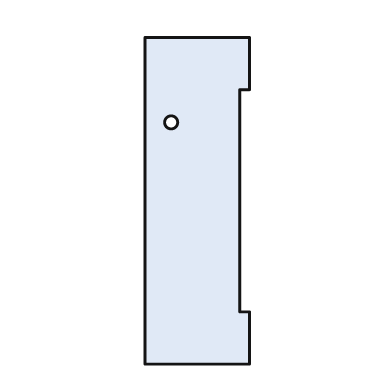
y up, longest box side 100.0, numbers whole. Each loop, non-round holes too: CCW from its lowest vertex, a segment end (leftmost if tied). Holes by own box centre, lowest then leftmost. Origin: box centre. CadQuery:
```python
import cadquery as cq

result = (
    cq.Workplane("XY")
    .moveTo(-16.0, -50.0)
    .lineTo(16.0, -50.0)
    .lineTo(16.0, -34.0)
    .lineTo(13.0, -34.0)
    .lineTo(13.0, 34.0)
    .lineTo(16.0, 34.0)
    .lineTo(16.0, 50.0)
    .lineTo(-16.0, 50.0)
    .close()
    .moveTo(-8.0, 24.0)
    .circle(2.0)
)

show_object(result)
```